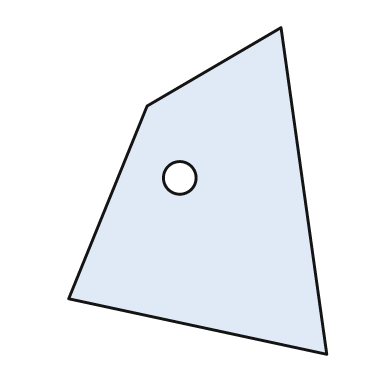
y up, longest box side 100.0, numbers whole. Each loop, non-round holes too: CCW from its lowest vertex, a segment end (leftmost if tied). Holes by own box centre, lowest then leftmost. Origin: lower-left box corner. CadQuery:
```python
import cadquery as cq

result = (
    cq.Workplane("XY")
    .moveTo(79.0, 0.0)
    .lineTo(65.0, 100.0)
    .lineTo(24.0, 76.0)
    .lineTo(0.0, 17.0)
    .close()
    .moveTo(34.0, 54.0)
    .circle(5.0)
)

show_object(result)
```